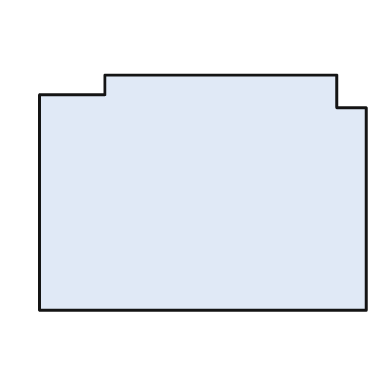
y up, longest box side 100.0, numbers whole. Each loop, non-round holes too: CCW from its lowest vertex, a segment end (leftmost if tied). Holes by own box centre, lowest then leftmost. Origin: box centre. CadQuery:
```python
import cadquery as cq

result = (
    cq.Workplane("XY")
    .moveTo(-50.0, -36.0)
    .lineTo(50.0, -36.0)
    .lineTo(50.0, 26.0)
    .lineTo(41.0, 26.0)
    .lineTo(41.0, 36.0)
    .lineTo(-30.0, 36.0)
    .lineTo(-30.0, 30.0)
    .lineTo(-50.0, 30.0)
    .close()
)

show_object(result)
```